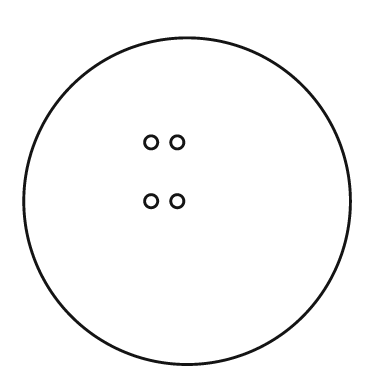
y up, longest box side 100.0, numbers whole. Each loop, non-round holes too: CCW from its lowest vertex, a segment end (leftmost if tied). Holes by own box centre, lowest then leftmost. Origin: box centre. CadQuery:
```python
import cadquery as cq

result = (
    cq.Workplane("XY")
    .moveTo(0.0, 0.0)
    .circle(50.0)
    .moveTo(-11.0, 0.0)
    .circle(2.0)
    .moveTo(-3.0, 0.0)
    .circle(2.0)
    .moveTo(-11.0, 18.0)
    .circle(2.0)
    .moveTo(-3.0, 18.0)
    .circle(2.0)
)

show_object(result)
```